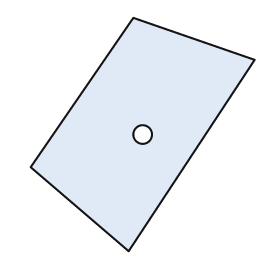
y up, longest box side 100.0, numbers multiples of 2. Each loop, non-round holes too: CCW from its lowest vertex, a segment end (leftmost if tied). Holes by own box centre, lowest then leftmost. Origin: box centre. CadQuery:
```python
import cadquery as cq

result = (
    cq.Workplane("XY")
    .moveTo(-6.0, -50.0)
    .lineTo(48.0, 32.0)
    .lineTo(-4.0, 50.0)
    .lineTo(-48.0, -14.0)
    .close()
    .moveTo(0.0, 0.0)
    .circle(4.0)
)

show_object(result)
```